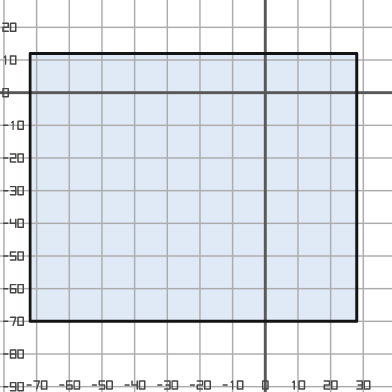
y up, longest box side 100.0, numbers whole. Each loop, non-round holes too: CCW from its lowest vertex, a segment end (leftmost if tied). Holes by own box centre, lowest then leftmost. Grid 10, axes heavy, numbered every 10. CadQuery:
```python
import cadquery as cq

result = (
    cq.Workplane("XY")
    .moveTo(-72.0, -70.0)
    .lineTo(28.0, -70.0)
    .lineTo(28.0, 12.0)
    .lineTo(-72.0, 12.0)
    .close()
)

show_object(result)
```